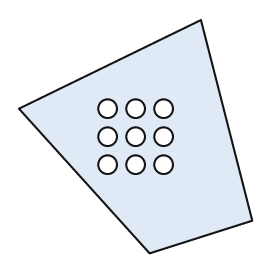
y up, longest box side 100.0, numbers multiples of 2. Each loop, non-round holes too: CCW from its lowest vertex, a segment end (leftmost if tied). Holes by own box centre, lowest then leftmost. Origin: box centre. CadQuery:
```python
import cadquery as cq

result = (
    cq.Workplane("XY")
    .moveTo(6.0, -50.0)
    .lineTo(50.0, -36.0)
    .lineTo(28.0, 50.0)
    .lineTo(-50.0, 12.0)
    .close()
    .moveTo(-12.0, -12.0)
    .circle(4.0)
    .moveTo(0.0, -12.0)
    .circle(4.0)
    .moveTo(12.0, -12.0)
    .circle(4.0)
    .moveTo(-12.0, 0.0)
    .circle(4.0)
    .moveTo(0.0, 0.0)
    .circle(4.0)
    .moveTo(12.0, 0.0)
    .circle(4.0)
    .moveTo(-12.0, 12.0)
    .circle(4.0)
    .moveTo(0.0, 12.0)
    .circle(4.0)
    .moveTo(12.0, 12.0)
    .circle(4.0)
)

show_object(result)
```